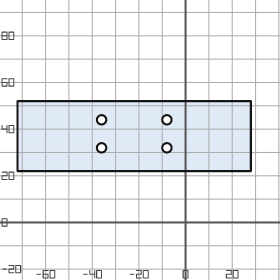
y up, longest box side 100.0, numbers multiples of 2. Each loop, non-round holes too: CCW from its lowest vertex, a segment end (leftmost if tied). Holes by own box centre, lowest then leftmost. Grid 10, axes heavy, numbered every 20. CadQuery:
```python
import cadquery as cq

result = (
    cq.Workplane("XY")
    .moveTo(-72.0, 22.0)
    .lineTo(28.0, 22.0)
    .lineTo(28.0, 52.0)
    .lineTo(-72.0, 52.0)
    .close()
    .moveTo(-36.0, 32.0)
    .circle(2.0)
    .moveTo(-8.0, 32.0)
    .circle(2.0)
    .moveTo(-36.0, 44.0)
    .circle(2.0)
    .moveTo(-8.0, 44.0)
    .circle(2.0)
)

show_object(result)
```